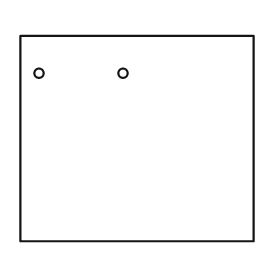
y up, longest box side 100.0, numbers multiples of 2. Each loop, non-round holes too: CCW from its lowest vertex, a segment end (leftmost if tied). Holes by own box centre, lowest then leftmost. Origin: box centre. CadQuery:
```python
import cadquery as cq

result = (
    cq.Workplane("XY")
    .moveTo(-50.0, -44.0)
    .lineTo(50.0, -44.0)
    .lineTo(50.0, 44.0)
    .lineTo(-50.0, 44.0)
    .close()
    .moveTo(-42.0, 28.0)
    .circle(2.0)
    .moveTo(-6.0, 28.0)
    .circle(2.0)
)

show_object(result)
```